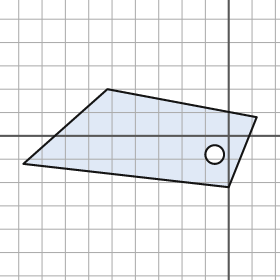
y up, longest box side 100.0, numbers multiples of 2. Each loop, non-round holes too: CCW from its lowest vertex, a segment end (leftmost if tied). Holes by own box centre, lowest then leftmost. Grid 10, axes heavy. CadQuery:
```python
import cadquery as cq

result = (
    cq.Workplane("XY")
    .moveTo(0.0, -22.0)
    .lineTo(12.0, 8.0)
    .lineTo(-52.0, 20.0)
    .lineTo(-88.0, -12.0)
    .close()
    .moveTo(-6.0, -8.0)
    .circle(4.0)
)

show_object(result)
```